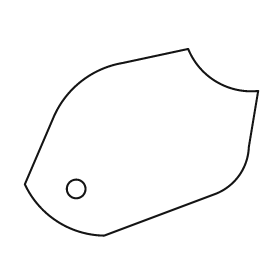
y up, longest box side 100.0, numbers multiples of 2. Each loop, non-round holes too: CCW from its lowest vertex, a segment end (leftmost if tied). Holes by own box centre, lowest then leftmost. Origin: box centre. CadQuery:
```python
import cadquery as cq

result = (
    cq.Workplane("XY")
    .moveTo(-16.0, -40.0)
    .lineTo(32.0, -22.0)
    .threePointArc((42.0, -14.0), (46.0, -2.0))
    .lineTo(50.0, 22.0)
    .threePointArc((32.0, 26.0), (20.0, 40.0))
    .lineTo(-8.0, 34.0)
    .threePointArc((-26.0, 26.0), (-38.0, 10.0))
    .lineTo(-50.0, -18.0)
    .threePointArc((-36.0, -34.0), (-16.0, -40.0))
    .close()
    .moveTo(-28.0, -20.0)
    .circle(4.0)
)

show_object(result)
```